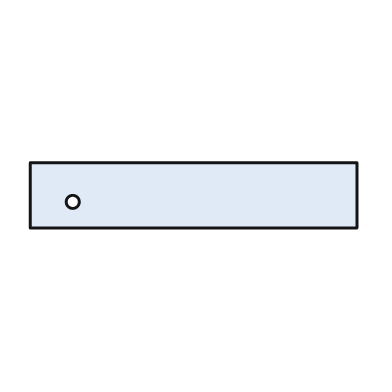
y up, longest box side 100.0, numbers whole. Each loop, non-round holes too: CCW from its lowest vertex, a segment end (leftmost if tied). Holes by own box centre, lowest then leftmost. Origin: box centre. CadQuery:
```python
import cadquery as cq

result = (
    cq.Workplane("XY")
    .moveTo(-50.0, -10.0)
    .lineTo(50.0, -10.0)
    .lineTo(50.0, 10.0)
    .lineTo(-50.0, 10.0)
    .close()
    .moveTo(-37.0, -2.0)
    .circle(2.0)
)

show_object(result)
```